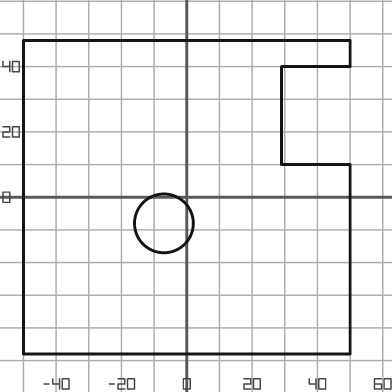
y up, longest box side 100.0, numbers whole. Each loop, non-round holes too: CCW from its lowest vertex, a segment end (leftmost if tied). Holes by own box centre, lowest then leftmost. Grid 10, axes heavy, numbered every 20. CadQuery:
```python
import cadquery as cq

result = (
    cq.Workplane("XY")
    .moveTo(-50.0, -48.0)
    .lineTo(50.0, -48.0)
    .lineTo(50.0, 10.0)
    .lineTo(29.0, 10.0)
    .lineTo(29.0, 40.0)
    .lineTo(50.0, 40.0)
    .lineTo(50.0, 48.0)
    .lineTo(-50.0, 48.0)
    .close()
    .moveTo(-7.0, -8.0)
    .circle(9.0)
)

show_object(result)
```